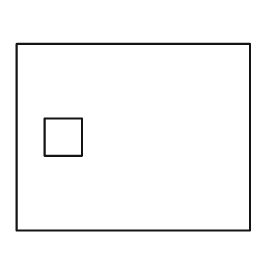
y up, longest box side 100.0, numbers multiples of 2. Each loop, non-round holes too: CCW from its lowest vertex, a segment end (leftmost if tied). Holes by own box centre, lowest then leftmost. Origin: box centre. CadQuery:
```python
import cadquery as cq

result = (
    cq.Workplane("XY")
    .moveTo(-50.0, -40.0)
    .lineTo(50.0, -40.0)
    .lineTo(50.0, 40.0)
    .lineTo(-50.0, 40.0)
    .close()
    .moveTo(-38.0, -8.0)
    .lineTo(-22.0, -8.0)
    .lineTo(-22.0, 8.0)
    .lineTo(-38.0, 8.0)
    .close()
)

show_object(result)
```